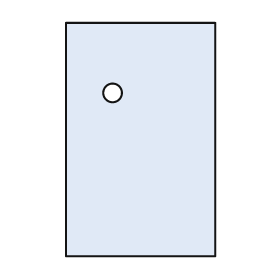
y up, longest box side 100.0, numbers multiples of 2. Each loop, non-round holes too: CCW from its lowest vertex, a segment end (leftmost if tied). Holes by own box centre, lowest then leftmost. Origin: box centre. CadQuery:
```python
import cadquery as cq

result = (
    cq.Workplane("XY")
    .moveTo(-32.0, -50.0)
    .lineTo(32.0, -50.0)
    .lineTo(32.0, 50.0)
    .lineTo(-32.0, 50.0)
    .close()
    .moveTo(-12.0, 20.0)
    .circle(4.0)
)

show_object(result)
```